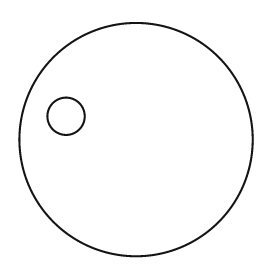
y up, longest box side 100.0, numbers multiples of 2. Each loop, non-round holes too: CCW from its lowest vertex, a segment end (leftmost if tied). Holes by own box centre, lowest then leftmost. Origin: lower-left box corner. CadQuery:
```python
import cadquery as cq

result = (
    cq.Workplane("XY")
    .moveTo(50.0, 50.0)
    .circle(50.0)
    .moveTo(20.0, 60.0)
    .circle(8.0)
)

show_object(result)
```